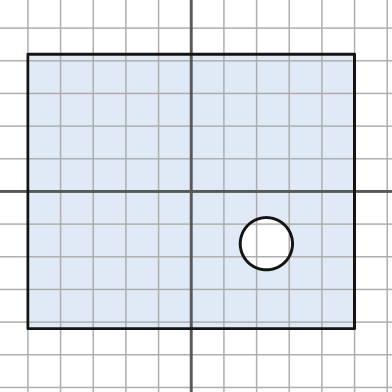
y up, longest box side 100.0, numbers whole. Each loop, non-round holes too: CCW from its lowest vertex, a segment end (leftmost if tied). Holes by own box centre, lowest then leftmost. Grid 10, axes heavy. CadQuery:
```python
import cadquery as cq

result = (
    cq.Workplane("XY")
    .moveTo(-50.0, -42.0)
    .lineTo(50.0, -42.0)
    .lineTo(50.0, 42.0)
    .lineTo(-50.0, 42.0)
    .close()
    .moveTo(23.0, -16.0)
    .circle(8.0)
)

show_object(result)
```